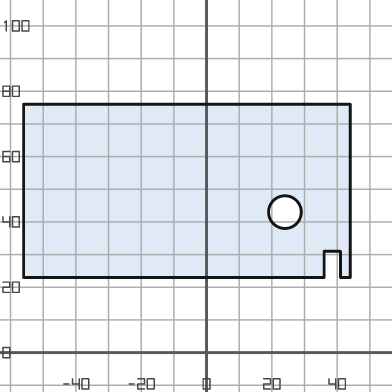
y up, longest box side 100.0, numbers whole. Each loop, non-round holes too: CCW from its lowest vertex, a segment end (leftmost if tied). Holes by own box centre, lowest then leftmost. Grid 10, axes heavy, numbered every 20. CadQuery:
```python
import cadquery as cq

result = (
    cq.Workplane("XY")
    .moveTo(-56.0, 23.0)
    .lineTo(36.0, 23.0)
    .lineTo(36.0, 31.0)
    .lineTo(41.0, 31.0)
    .lineTo(41.0, 23.0)
    .lineTo(44.0, 23.0)
    .lineTo(44.0, 76.0)
    .lineTo(-56.0, 76.0)
    .close()
    .moveTo(24.0, 43.0)
    .circle(5.0)
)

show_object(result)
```